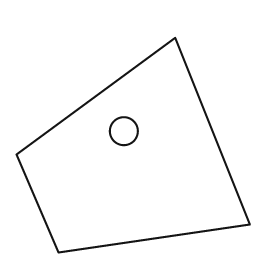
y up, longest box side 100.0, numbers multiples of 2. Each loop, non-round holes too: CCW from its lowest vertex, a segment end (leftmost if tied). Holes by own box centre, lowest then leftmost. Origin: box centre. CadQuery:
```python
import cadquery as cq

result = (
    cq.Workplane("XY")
    .moveTo(-32.0, -46.0)
    .lineTo(50.0, -34.0)
    .lineTo(18.0, 46.0)
    .lineTo(-50.0, -4.0)
    .close()
    .moveTo(-4.0, 6.0)
    .circle(6.0)
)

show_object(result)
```